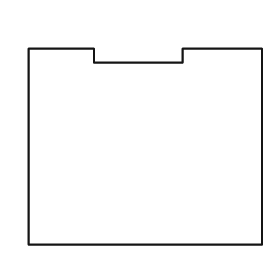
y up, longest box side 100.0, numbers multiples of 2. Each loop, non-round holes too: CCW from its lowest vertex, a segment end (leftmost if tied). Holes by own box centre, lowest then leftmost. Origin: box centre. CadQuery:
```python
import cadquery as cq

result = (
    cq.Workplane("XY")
    .moveTo(-50.0, -42.0)
    .lineTo(50.0, -42.0)
    .lineTo(50.0, 42.0)
    .lineTo(16.0, 42.0)
    .lineTo(16.0, 36.0)
    .lineTo(-22.0, 36.0)
    .lineTo(-22.0, 42.0)
    .lineTo(-50.0, 42.0)
    .close()
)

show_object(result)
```